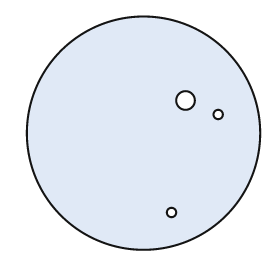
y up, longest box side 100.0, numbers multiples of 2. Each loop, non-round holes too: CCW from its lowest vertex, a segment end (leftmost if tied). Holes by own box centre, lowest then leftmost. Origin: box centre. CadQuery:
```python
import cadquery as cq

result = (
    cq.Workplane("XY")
    .moveTo(0.0, 0.0)
    .circle(50.0)
    .moveTo(12.0, -34.0)
    .circle(2.0)
    .moveTo(32.0, 8.0)
    .circle(2.0)
    .moveTo(18.0, 14.0)
    .circle(4.0)
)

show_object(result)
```